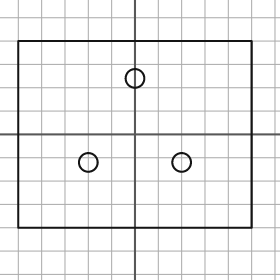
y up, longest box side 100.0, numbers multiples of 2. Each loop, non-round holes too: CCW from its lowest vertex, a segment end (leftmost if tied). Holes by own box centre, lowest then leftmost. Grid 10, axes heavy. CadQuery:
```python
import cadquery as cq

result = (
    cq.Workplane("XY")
    .moveTo(-50.0, -40.0)
    .lineTo(50.0, -40.0)
    .lineTo(50.0, 40.0)
    .lineTo(-50.0, 40.0)
    .close()
    .moveTo(-20.0, -12.0)
    .circle(4.0)
    .moveTo(20.0, -12.0)
    .circle(4.0)
    .moveTo(0.0, 24.0)
    .circle(4.0)
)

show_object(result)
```